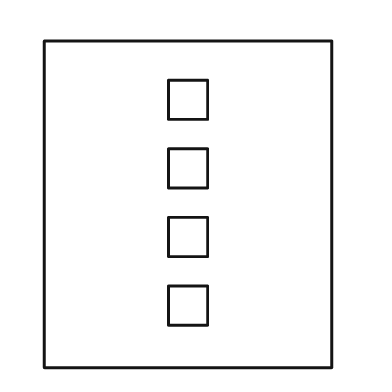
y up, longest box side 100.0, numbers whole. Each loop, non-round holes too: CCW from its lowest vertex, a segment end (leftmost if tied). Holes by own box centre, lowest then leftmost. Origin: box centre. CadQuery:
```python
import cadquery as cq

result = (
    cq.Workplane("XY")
    .moveTo(-44.0, -50.0)
    .lineTo(44.0, -50.0)
    .lineTo(44.0, 50.0)
    .lineTo(-44.0, 50.0)
    .close()
    .moveTo(-6.0, -37.0)
    .lineTo(6.0, -37.0)
    .lineTo(6.0, -25.0)
    .lineTo(-6.0, -25.0)
    .close()
    .moveTo(-6.0, -16.0)
    .lineTo(6.0, -16.0)
    .lineTo(6.0, -4.0)
    .lineTo(-6.0, -4.0)
    .close()
    .moveTo(-6.0, 5.0)
    .lineTo(6.0, 5.0)
    .lineTo(6.0, 17.0)
    .lineTo(-6.0, 17.0)
    .close()
    .moveTo(-6.0, 26.0)
    .lineTo(6.0, 26.0)
    .lineTo(6.0, 38.0)
    .lineTo(-6.0, 38.0)
    .close()
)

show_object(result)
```